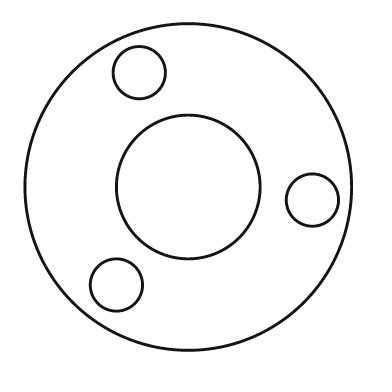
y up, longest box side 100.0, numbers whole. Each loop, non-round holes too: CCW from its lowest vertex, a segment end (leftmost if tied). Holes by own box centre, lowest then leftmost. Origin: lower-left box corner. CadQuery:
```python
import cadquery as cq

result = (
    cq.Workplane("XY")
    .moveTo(50.0, 50.0)
    .circle(50.0)
    .moveTo(28.0, 20.0)
    .circle(8.0)
    .moveTo(88.0, 46.0)
    .circle(8.0)
    .moveTo(50.0, 50.0)
    .circle(22.0)
    .moveTo(35.0, 85.0)
    .circle(8.0)
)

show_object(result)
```